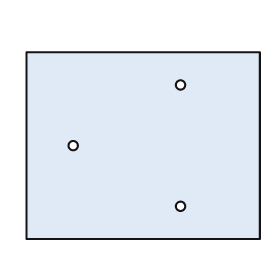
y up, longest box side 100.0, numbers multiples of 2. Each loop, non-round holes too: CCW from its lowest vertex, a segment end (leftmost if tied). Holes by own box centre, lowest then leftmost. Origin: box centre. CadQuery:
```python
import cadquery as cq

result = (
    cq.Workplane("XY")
    .moveTo(-50.0, -40.0)
    .lineTo(50.0, -40.0)
    .lineTo(50.0, 40.0)
    .lineTo(-50.0, 40.0)
    .close()
    .moveTo(16.0, -26.0)
    .circle(2.0)
    .moveTo(-30.0, 0.0)
    .circle(2.0)
    .moveTo(16.0, 26.0)
    .circle(2.0)
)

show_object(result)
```